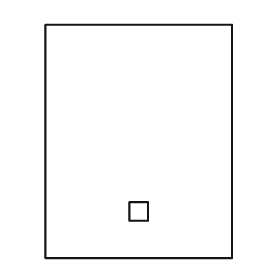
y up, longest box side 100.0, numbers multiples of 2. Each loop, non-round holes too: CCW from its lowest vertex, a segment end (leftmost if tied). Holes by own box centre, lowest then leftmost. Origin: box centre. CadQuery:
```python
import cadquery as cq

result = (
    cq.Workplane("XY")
    .moveTo(-40.0, -50.0)
    .lineTo(40.0, -50.0)
    .lineTo(40.0, 50.0)
    .lineTo(-40.0, 50.0)
    .close()
    .moveTo(-4.0, -34.0)
    .lineTo(4.0, -34.0)
    .lineTo(4.0, -26.0)
    .lineTo(-4.0, -26.0)
    .close()
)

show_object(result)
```